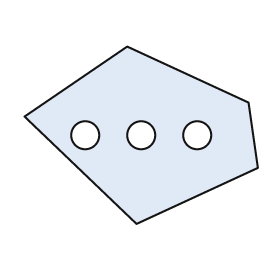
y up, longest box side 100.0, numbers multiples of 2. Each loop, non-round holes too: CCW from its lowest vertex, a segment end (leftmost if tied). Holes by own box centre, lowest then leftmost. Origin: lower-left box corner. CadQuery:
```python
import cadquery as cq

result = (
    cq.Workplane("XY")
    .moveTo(48.0, 0.0)
    .lineTo(100.0, 24.0)
    .lineTo(96.0, 52.0)
    .lineTo(44.0, 76.0)
    .lineTo(0.0, 46.0)
    .close()
    .moveTo(26.0, 38.0)
    .circle(6.0)
    .moveTo(50.0, 38.0)
    .circle(6.0)
    .moveTo(74.0, 38.0)
    .circle(6.0)
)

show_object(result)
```